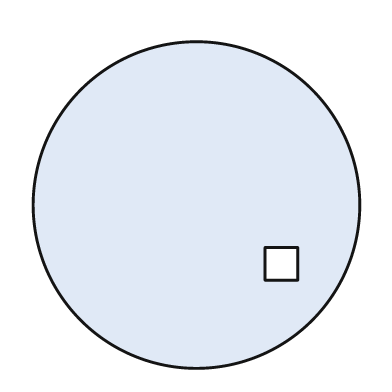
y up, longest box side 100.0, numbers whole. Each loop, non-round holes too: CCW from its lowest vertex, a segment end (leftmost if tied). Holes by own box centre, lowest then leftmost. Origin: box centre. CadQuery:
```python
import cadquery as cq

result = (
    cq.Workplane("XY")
    .moveTo(0.0, 0.0)
    .circle(50.0)
    .moveTo(21.0, -23.0)
    .lineTo(31.0, -23.0)
    .lineTo(31.0, -13.0)
    .lineTo(21.0, -13.0)
    .close()
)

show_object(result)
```